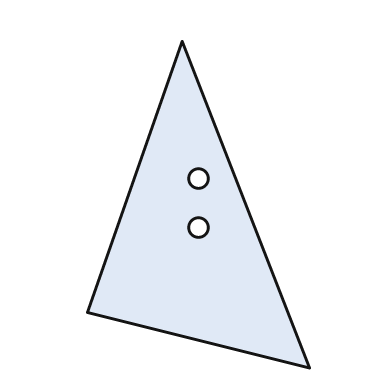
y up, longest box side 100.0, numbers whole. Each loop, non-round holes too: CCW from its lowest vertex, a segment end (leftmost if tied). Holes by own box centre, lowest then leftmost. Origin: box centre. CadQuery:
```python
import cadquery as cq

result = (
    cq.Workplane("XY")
    .moveTo(34.0, -50.0)
    .lineTo(-5.0, 50.0)
    .lineTo(-34.0, -33.0)
    .close()
    .moveTo(0.0, -7.0)
    .circle(3.0)
    .moveTo(0.0, 8.0)
    .circle(3.0)
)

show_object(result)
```